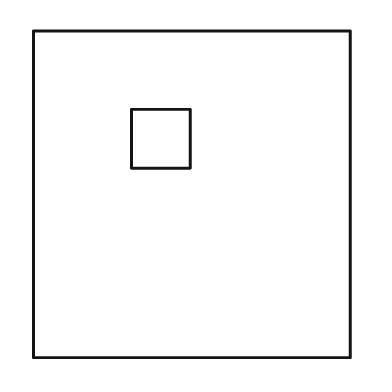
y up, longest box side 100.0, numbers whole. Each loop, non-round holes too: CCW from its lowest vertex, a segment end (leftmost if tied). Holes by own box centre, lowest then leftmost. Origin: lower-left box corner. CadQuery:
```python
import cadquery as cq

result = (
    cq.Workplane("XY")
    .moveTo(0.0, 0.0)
    .lineTo(97.0, 0.0)
    .lineTo(97.0, 100.0)
    .lineTo(0.0, 100.0)
    .close()
    .moveTo(30.0, 58.0)
    .lineTo(48.0, 58.0)
    .lineTo(48.0, 76.0)
    .lineTo(30.0, 76.0)
    .close()
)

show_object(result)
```